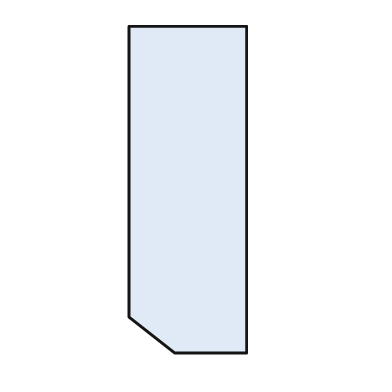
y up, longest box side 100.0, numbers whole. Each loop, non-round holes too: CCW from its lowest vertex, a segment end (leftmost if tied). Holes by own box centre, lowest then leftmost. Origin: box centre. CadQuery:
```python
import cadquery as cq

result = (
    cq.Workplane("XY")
    .moveTo(-4.0, -50.0)
    .lineTo(18.0, -50.0)
    .lineTo(18.0, 50.0)
    .lineTo(-18.0, 50.0)
    .lineTo(-18.0, -39.0)
    .close()
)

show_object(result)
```